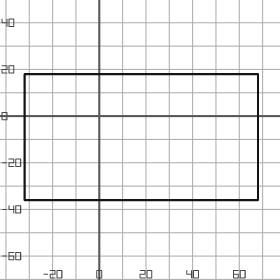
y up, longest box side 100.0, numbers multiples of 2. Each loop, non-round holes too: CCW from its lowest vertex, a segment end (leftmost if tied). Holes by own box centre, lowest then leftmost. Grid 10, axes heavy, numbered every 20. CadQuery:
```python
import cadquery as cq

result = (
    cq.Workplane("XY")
    .moveTo(-32.0, -36.0)
    .lineTo(68.0, -36.0)
    .lineTo(68.0, 18.0)
    .lineTo(-32.0, 18.0)
    .close()
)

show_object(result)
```